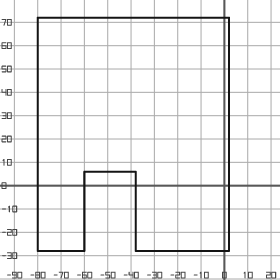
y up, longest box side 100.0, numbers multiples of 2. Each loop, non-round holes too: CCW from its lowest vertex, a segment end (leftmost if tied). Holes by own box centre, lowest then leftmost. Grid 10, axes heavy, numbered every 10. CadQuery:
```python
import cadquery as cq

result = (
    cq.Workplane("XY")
    .moveTo(-80.0, -28.0)
    .lineTo(-60.0, -28.0)
    .lineTo(-60.0, 6.0)
    .lineTo(-38.0, 6.0)
    .lineTo(-38.0, -28.0)
    .lineTo(2.0, -28.0)
    .lineTo(2.0, 72.0)
    .lineTo(-80.0, 72.0)
    .close()
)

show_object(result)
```